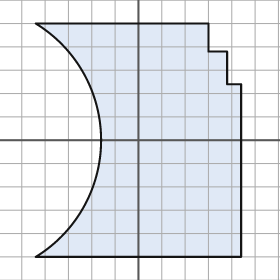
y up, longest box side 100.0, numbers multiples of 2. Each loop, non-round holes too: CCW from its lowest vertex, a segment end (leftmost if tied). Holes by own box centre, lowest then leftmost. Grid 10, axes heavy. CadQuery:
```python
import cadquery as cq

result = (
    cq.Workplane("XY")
    .moveTo(-44.0, -50.0)
    .lineTo(44.0, -50.0)
    .lineTo(44.0, 24.0)
    .lineTo(38.0, 24.0)
    .lineTo(38.0, 38.0)
    .lineTo(30.0, 38.0)
    .lineTo(30.0, 50.0)
    .lineTo(-44.0, 50.0)
    .threePointArc((-16.0, 0.0), (-44.0, -50.0))
    .close()
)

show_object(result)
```